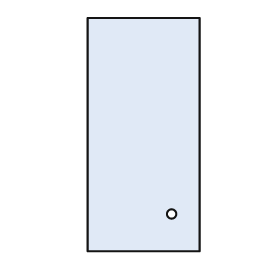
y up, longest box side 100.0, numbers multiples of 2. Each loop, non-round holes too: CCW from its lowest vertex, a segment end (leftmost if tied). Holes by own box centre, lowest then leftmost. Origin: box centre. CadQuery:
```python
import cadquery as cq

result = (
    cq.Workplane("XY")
    .moveTo(-24.0, -50.0)
    .lineTo(24.0, -50.0)
    .lineTo(24.0, 50.0)
    .lineTo(-24.0, 50.0)
    .close()
    .moveTo(12.0, -34.0)
    .circle(2.0)
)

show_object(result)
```